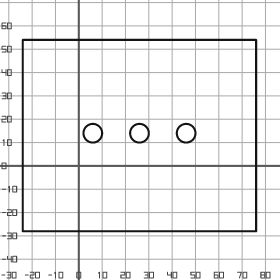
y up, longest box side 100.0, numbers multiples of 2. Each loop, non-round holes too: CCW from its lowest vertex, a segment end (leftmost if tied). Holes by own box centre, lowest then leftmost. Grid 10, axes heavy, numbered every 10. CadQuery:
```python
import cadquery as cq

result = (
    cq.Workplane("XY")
    .moveTo(-24.0, -28.0)
    .lineTo(76.0, -28.0)
    .lineTo(76.0, 54.0)
    .lineTo(-24.0, 54.0)
    .close()
    .moveTo(6.0, 14.0)
    .circle(4.0)
    .moveTo(26.0, 14.0)
    .circle(4.0)
    .moveTo(46.0, 14.0)
    .circle(4.0)
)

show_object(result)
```